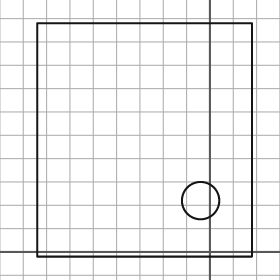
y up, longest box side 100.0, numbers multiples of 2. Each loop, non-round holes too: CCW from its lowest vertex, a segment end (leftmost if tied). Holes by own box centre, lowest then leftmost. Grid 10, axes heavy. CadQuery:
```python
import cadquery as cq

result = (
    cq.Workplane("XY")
    .moveTo(-74.0, -2.0)
    .lineTo(18.0, -2.0)
    .lineTo(18.0, 98.0)
    .lineTo(-74.0, 98.0)
    .close()
    .moveTo(-4.0, 22.0)
    .circle(8.0)
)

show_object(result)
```